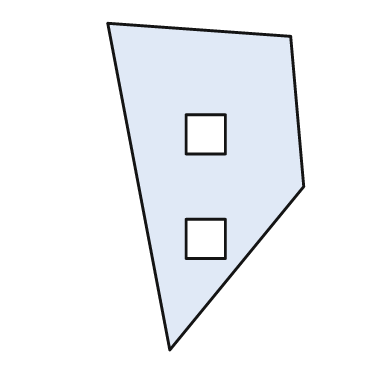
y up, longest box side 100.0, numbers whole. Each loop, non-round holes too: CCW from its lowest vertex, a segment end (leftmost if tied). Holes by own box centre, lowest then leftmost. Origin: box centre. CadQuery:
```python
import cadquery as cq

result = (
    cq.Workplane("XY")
    .moveTo(-11.0, -50.0)
    .lineTo(30.0, 0.0)
    .lineTo(26.0, 46.0)
    .lineTo(-30.0, 50.0)
    .close()
    .moveTo(-6.0, -22.0)
    .lineTo(6.0, -22.0)
    .lineTo(6.0, -10.0)
    .lineTo(-6.0, -10.0)
    .close()
    .moveTo(-6.0, 10.0)
    .lineTo(6.0, 10.0)
    .lineTo(6.0, 22.0)
    .lineTo(-6.0, 22.0)
    .close()
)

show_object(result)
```